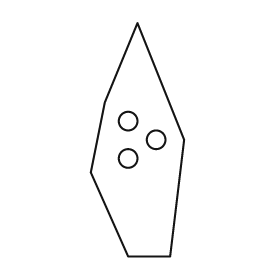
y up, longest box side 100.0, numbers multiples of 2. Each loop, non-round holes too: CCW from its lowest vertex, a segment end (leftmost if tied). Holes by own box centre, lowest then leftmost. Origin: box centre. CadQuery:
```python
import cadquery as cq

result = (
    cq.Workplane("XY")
    .moveTo(-4.0, -50.0)
    .lineTo(14.0, -50.0)
    .lineTo(20.0, 0.0)
    .lineTo(0.0, 50.0)
    .lineTo(-14.0, 16.0)
    .lineTo(-20.0, -14.0)
    .close()
    .moveTo(-4.0, -8.0)
    .circle(4.0)
    .moveTo(8.0, 0.0)
    .circle(4.0)
    .moveTo(-4.0, 8.0)
    .circle(4.0)
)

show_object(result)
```